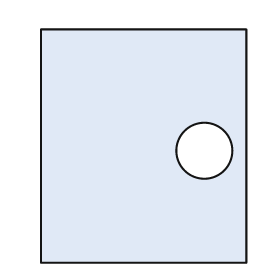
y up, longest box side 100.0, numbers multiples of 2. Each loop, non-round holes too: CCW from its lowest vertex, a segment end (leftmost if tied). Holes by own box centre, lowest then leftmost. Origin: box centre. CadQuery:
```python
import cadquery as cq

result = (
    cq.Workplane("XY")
    .moveTo(-44.0, -50.0)
    .lineTo(44.0, -50.0)
    .lineTo(44.0, 50.0)
    .lineTo(-44.0, 50.0)
    .close()
    .moveTo(26.0, -2.0)
    .circle(12.0)
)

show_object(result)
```